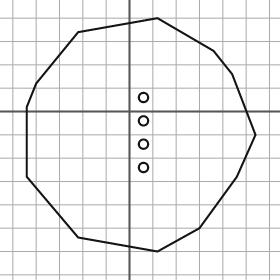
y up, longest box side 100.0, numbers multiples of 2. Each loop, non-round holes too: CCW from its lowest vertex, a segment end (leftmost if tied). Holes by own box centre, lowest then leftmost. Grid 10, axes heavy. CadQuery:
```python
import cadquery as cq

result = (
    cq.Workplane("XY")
    .moveTo(12.0, -60.0)
    .lineTo(30.0, -50.0)
    .lineTo(46.0, -28.0)
    .lineTo(54.0, -10.0)
    .lineTo(44.0, 16.0)
    .lineTo(36.0, 26.0)
    .lineTo(12.0, 40.0)
    .lineTo(-22.0, 34.0)
    .lineTo(-40.0, 12.0)
    .lineTo(-44.0, 2.0)
    .lineTo(-44.0, -28.0)
    .lineTo(-22.0, -54.0)
    .close()
    .moveTo(6.0, -24.0)
    .circle(2.0)
    .moveTo(6.0, -14.0)
    .circle(2.0)
    .moveTo(6.0, -4.0)
    .circle(2.0)
    .moveTo(6.0, 6.0)
    .circle(2.0)
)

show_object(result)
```